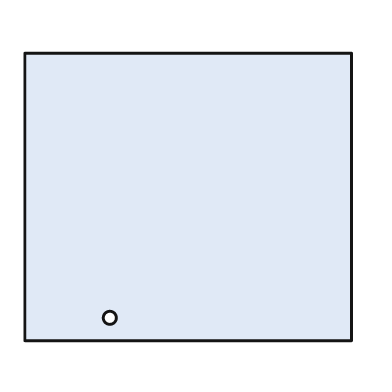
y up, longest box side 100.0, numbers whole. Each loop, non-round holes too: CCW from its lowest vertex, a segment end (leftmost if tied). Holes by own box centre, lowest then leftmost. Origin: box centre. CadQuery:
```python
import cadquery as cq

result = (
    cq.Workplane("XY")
    .moveTo(-50.0, -44.0)
    .lineTo(50.0, -44.0)
    .lineTo(50.0, 44.0)
    .lineTo(-50.0, 44.0)
    .close()
    .moveTo(-24.0, -37.0)
    .circle(2.0)
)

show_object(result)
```